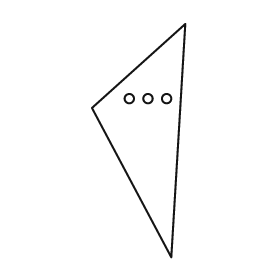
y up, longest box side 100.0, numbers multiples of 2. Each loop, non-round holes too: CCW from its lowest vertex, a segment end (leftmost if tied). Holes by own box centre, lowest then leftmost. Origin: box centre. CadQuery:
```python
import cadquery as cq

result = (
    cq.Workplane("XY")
    .moveTo(14.0, -50.0)
    .lineTo(20.0, 50.0)
    .lineTo(-20.0, 14.0)
    .close()
    .moveTo(-4.0, 18.0)
    .circle(2.0)
    .moveTo(4.0, 18.0)
    .circle(2.0)
    .moveTo(12.0, 18.0)
    .circle(2.0)
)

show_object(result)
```